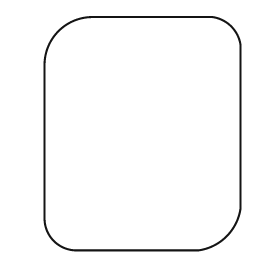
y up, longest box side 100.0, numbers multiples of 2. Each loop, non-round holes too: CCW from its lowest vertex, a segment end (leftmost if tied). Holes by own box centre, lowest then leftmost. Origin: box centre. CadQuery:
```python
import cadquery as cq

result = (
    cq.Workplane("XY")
    .moveTo(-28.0, -50.0)
    .lineTo(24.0, -50.0)
    .threePointArc((36.0, -44.0), (42.0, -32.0))
    .lineTo(42.0, 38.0)
    .threePointArc((38.0, 46.0), (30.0, 50.0))
    .lineTo(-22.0, 50.0)
    .threePointArc((-36.0, 44.0), (-42.0, 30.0))
    .lineTo(-42.0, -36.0)
    .threePointArc((-38.0, -46.0), (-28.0, -50.0))
    .close()
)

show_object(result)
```